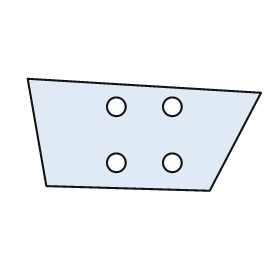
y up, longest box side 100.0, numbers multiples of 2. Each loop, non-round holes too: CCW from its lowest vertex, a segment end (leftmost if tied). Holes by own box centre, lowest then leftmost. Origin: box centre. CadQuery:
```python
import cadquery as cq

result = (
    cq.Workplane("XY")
    .moveTo(28.0, -24.0)
    .lineTo(50.0, 18.0)
    .lineTo(-50.0, 24.0)
    .lineTo(-42.0, -22.0)
    .close()
    .moveTo(-12.0, -12.0)
    .circle(4.0)
    .moveTo(12.0, -12.0)
    .circle(4.0)
    .moveTo(-12.0, 12.0)
    .circle(4.0)
    .moveTo(12.0, 12.0)
    .circle(4.0)
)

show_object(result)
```